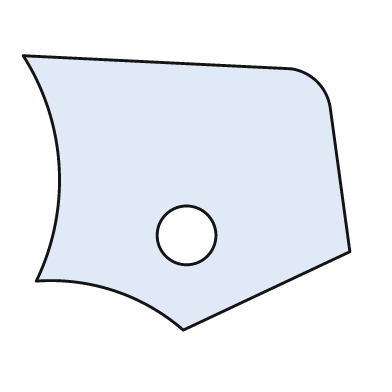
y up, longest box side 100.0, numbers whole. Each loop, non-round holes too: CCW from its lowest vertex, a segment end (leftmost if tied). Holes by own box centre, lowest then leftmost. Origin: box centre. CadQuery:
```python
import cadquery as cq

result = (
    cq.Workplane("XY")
    .moveTo(-1.0, -42.0)
    .lineTo(50.0, -18.0)
    .lineTo(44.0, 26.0)
    .threePointArc((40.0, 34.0), (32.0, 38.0))
    .lineTo(-50.0, 42.0)
    .threePointArc((-39.0, 8.0), (-46.0, -27.0))
    .threePointArc((-22.0, -30.0), (-1.0, -42.0))
    .close()
    .moveTo(0.0, -13.0)
    .circle(9.0)
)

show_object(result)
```